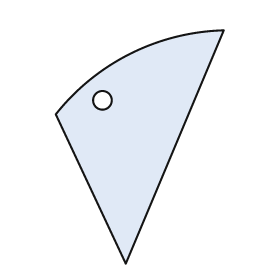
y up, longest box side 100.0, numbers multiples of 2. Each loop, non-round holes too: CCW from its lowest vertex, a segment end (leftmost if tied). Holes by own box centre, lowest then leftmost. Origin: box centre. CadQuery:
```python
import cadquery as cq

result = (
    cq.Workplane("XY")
    .moveTo(-6.0, -50.0)
    .lineTo(36.0, 50.0)
    .threePointArc((-4.0, 40.0), (-36.0, 14.0))
    .close()
    .moveTo(-16.0, 20.0)
    .circle(4.0)
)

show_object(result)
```